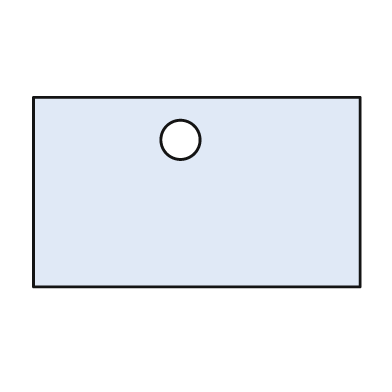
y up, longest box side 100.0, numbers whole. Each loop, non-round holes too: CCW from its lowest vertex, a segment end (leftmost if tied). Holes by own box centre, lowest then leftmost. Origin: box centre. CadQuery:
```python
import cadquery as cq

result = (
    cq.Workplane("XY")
    .moveTo(-50.0, -29.0)
    .lineTo(50.0, -29.0)
    .lineTo(50.0, 29.0)
    .lineTo(-50.0, 29.0)
    .close()
    .moveTo(-5.0, 16.0)
    .circle(6.0)
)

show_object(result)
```